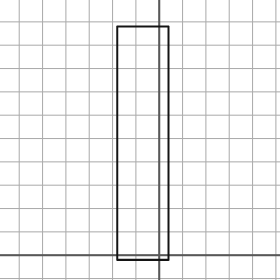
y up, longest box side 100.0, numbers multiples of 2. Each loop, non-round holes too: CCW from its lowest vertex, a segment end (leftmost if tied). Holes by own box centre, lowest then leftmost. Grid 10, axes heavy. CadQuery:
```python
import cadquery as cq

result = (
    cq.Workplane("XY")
    .moveTo(-18.0, -2.0)
    .lineTo(4.0, -2.0)
    .lineTo(4.0, 98.0)
    .lineTo(-18.0, 98.0)
    .close()
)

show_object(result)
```